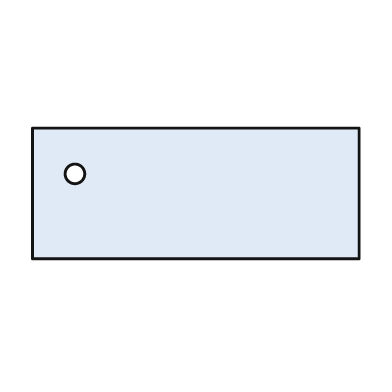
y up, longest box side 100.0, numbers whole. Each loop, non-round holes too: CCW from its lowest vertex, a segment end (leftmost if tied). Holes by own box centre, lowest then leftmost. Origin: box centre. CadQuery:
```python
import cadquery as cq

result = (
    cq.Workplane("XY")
    .moveTo(-50.0, -20.0)
    .lineTo(50.0, -20.0)
    .lineTo(50.0, 20.0)
    .lineTo(-50.0, 20.0)
    .close()
    .moveTo(-37.0, 6.0)
    .circle(3.0)
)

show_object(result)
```